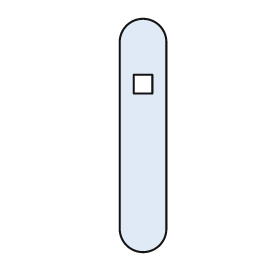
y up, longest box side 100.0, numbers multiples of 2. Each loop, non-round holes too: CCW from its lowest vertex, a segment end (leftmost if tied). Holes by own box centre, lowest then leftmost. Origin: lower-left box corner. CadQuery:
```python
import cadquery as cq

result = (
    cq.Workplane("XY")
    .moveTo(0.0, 10.0)
    .threePointArc((10.0, 0.0), (20.0, 10.0))
    .lineTo(20.0, 90.0)
    .threePointArc((10.0, 100.0), (0.0, 90.0))
    .close()
    .moveTo(6.0, 68.0)
    .lineTo(14.0, 68.0)
    .lineTo(14.0, 76.0)
    .lineTo(6.0, 76.0)
    .close()
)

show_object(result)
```